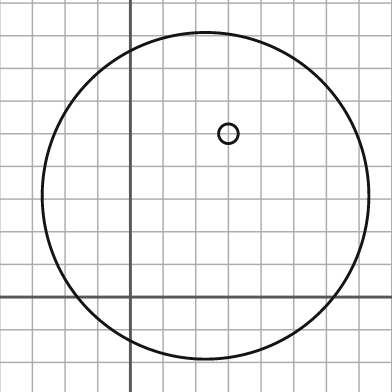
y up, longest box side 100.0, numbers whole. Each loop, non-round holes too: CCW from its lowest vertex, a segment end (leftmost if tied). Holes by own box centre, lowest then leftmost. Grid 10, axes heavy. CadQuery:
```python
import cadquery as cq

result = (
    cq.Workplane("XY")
    .moveTo(23.0, 31.0)
    .circle(50.0)
    .moveTo(30.0, 50.0)
    .circle(3.0)
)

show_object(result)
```